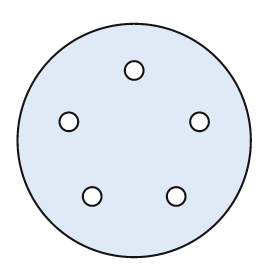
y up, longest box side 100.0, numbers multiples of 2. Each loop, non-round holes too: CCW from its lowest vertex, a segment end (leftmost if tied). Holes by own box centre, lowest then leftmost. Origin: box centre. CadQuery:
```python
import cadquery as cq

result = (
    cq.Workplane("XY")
    .moveTo(0.0, 0.0)
    .circle(50.0)
    .moveTo(-18.0, -24.0)
    .circle(4.0)
    .moveTo(18.0, -24.0)
    .circle(4.0)
    .moveTo(-28.0, 8.0)
    .circle(4.0)
    .moveTo(28.0, 8.0)
    .circle(4.0)
    .moveTo(0.0, 30.0)
    .circle(4.0)
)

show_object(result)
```